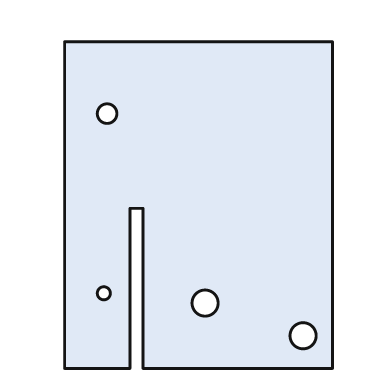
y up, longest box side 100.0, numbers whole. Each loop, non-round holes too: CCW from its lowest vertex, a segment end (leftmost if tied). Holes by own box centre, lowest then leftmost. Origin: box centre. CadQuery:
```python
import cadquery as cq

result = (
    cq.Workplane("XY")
    .moveTo(-41.0, -50.0)
    .lineTo(-21.0, -50.0)
    .lineTo(-21.0, -1.0)
    .lineTo(-17.0, -1.0)
    .lineTo(-17.0, -50.0)
    .lineTo(41.0, -50.0)
    .lineTo(41.0, 50.0)
    .lineTo(-41.0, 50.0)
    .close()
    .moveTo(32.0, -40.0)
    .circle(4.0)
    .moveTo(2.0, -30.0)
    .circle(4.0)
    .moveTo(-29.0, -27.0)
    .circle(2.0)
    .moveTo(-28.0, 28.0)
    .circle(3.0)
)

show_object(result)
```